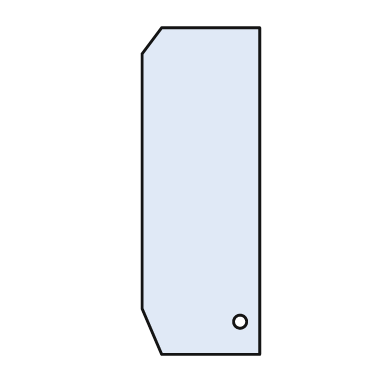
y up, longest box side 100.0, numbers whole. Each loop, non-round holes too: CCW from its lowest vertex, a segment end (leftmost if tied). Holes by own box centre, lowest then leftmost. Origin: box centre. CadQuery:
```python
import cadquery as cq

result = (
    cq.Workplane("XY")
    .moveTo(-12.0, -50.0)
    .lineTo(18.0, -50.0)
    .lineTo(18.0, 50.0)
    .lineTo(-12.0, 50.0)
    .lineTo(-18.0, 42.0)
    .lineTo(-18.0, -36.0)
    .close()
    .moveTo(12.0, -40.0)
    .circle(2.0)
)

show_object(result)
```